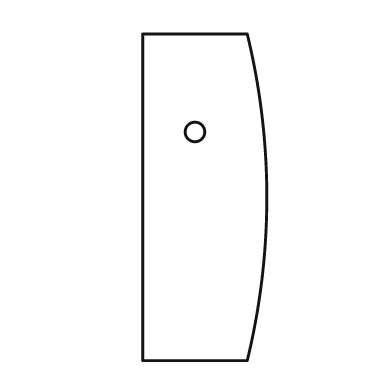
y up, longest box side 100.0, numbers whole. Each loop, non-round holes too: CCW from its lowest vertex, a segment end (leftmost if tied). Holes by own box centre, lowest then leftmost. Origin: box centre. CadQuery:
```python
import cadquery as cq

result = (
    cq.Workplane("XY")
    .moveTo(-19.0, -50.0)
    .lineTo(13.0, -50.0)
    .threePointArc((19.0, 0.0), (13.0, 50.0))
    .lineTo(-19.0, 50.0)
    .close()
    .moveTo(-3.0, 20.0)
    .circle(3.0)
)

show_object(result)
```